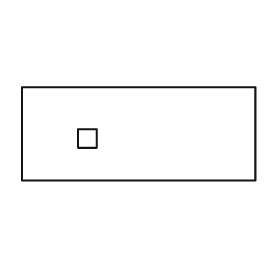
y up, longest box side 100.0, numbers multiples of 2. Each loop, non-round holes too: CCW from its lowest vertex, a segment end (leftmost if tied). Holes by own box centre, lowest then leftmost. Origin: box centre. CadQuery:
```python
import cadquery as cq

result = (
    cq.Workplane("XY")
    .moveTo(-50.0, -20.0)
    .lineTo(50.0, -20.0)
    .lineTo(50.0, 20.0)
    .lineTo(-50.0, 20.0)
    .close()
    .moveTo(-26.0, -6.0)
    .lineTo(-18.0, -6.0)
    .lineTo(-18.0, 2.0)
    .lineTo(-26.0, 2.0)
    .close()
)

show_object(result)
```